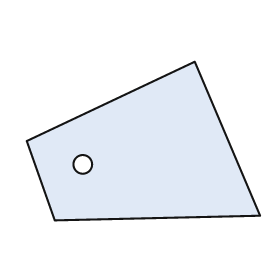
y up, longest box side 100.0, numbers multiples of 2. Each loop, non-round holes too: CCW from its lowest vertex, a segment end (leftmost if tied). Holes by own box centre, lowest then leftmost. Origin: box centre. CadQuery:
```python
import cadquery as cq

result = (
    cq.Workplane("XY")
    .moveTo(-38.0, -34.0)
    .lineTo(50.0, -32.0)
    .lineTo(22.0, 34.0)
    .lineTo(-50.0, 0.0)
    .close()
    .moveTo(-26.0, -10.0)
    .circle(4.0)
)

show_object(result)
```